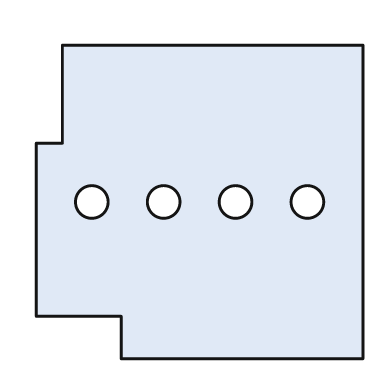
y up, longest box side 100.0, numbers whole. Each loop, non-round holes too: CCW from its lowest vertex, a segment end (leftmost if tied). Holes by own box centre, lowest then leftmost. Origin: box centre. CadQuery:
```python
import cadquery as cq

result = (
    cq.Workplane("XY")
    .moveTo(-24.0, -48.0)
    .lineTo(50.0, -48.0)
    .lineTo(50.0, 48.0)
    .lineTo(-42.0, 48.0)
    .lineTo(-42.0, 18.0)
    .lineTo(-50.0, 18.0)
    .lineTo(-50.0, -35.0)
    .lineTo(-24.0, -35.0)
    .close()
    .moveTo(-33.0, 0.0)
    .circle(5.0)
    .moveTo(-11.0, 0.0)
    .circle(5.0)
    .moveTo(11.0, 0.0)
    .circle(5.0)
    .moveTo(33.0, 0.0)
    .circle(5.0)
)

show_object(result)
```